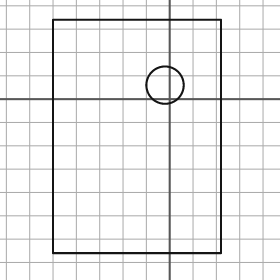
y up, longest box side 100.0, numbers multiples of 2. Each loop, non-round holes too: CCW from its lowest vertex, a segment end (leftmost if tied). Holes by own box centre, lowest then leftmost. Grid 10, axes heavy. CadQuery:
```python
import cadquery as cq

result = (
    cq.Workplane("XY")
    .moveTo(-50.0, -66.0)
    .lineTo(22.0, -66.0)
    .lineTo(22.0, 34.0)
    .lineTo(-50.0, 34.0)
    .close()
    .moveTo(-2.0, 6.0)
    .circle(8.0)
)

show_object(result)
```